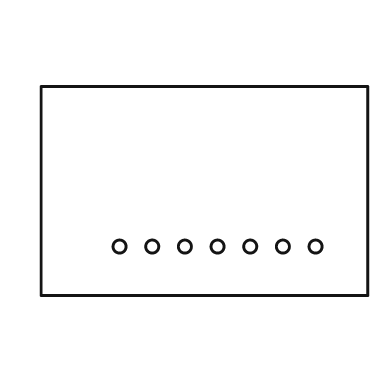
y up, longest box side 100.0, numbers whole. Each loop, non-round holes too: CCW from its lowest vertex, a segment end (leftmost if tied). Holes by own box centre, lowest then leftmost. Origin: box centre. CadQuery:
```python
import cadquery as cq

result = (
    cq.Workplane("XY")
    .moveTo(-50.0, -32.0)
    .lineTo(50.0, -32.0)
    .lineTo(50.0, 32.0)
    .lineTo(-50.0, 32.0)
    .close()
    .moveTo(-26.0, -17.0)
    .circle(2.0)
    .moveTo(-16.0, -17.0)
    .circle(2.0)
    .moveTo(-6.0, -17.0)
    .circle(2.0)
    .moveTo(4.0, -17.0)
    .circle(2.0)
    .moveTo(14.0, -17.0)
    .circle(2.0)
    .moveTo(24.0, -17.0)
    .circle(2.0)
    .moveTo(34.0, -17.0)
    .circle(2.0)
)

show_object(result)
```